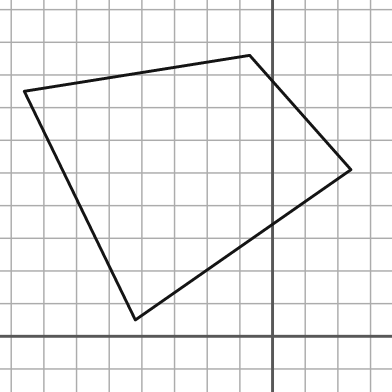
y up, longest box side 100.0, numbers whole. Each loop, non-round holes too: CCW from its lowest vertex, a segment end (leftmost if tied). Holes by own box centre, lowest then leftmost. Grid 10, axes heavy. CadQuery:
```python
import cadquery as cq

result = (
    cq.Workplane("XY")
    .moveTo(-42.0, 5.0)
    .lineTo(24.0, 51.0)
    .lineTo(-7.0, 86.0)
    .lineTo(-76.0, 75.0)
    .close()
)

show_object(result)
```